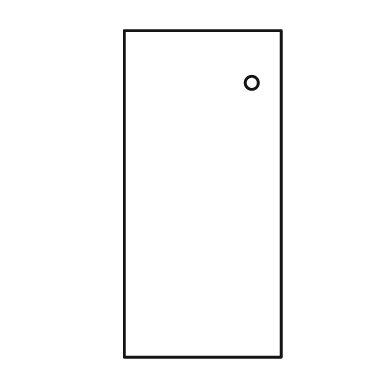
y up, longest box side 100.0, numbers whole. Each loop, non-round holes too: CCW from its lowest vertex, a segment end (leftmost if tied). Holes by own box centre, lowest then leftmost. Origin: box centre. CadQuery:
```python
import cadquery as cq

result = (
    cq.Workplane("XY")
    .moveTo(-24.0, -50.0)
    .lineTo(24.0, -50.0)
    .lineTo(24.0, 50.0)
    .lineTo(-24.0, 50.0)
    .close()
    .moveTo(15.0, 34.0)
    .circle(2.0)
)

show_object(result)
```